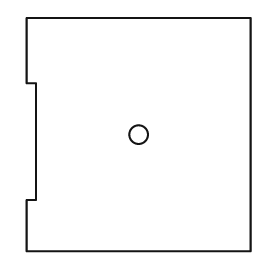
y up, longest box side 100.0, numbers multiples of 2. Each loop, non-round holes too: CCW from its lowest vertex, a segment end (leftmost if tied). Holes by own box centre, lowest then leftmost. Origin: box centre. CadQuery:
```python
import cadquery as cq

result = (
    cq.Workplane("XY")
    .moveTo(-48.0, -50.0)
    .lineTo(48.0, -50.0)
    .lineTo(48.0, 50.0)
    .lineTo(-48.0, 50.0)
    .lineTo(-48.0, 22.0)
    .lineTo(-44.0, 22.0)
    .lineTo(-44.0, -28.0)
    .lineTo(-48.0, -28.0)
    .close()
    .moveTo(0.0, 0.0)
    .circle(4.0)
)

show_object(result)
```